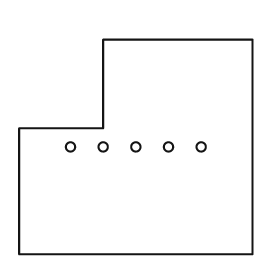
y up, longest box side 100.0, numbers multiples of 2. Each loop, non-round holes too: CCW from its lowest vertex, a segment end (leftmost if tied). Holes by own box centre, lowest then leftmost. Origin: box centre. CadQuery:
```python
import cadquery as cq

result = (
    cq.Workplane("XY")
    .moveTo(-50.0, -46.0)
    .lineTo(50.0, -46.0)
    .lineTo(50.0, 46.0)
    .lineTo(-14.0, 46.0)
    .lineTo(-14.0, 8.0)
    .lineTo(-50.0, 8.0)
    .close()
    .moveTo(-28.0, 0.0)
    .circle(2.0)
    .moveTo(-14.0, 0.0)
    .circle(2.0)
    .moveTo(0.0, 0.0)
    .circle(2.0)
    .moveTo(14.0, 0.0)
    .circle(2.0)
    .moveTo(28.0, 0.0)
    .circle(2.0)
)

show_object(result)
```